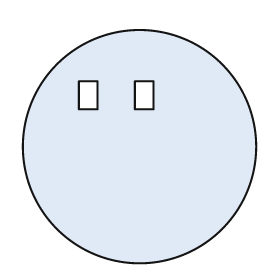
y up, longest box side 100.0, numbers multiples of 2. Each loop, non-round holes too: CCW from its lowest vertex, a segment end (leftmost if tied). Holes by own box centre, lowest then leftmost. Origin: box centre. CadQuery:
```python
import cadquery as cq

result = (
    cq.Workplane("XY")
    .moveTo(0.0, 0.0)
    .circle(50.0)
    .moveTo(-26.0, 16.0)
    .lineTo(-18.0, 16.0)
    .lineTo(-18.0, 28.0)
    .lineTo(-26.0, 28.0)
    .close()
    .moveTo(-2.0, 16.0)
    .lineTo(6.0, 16.0)
    .lineTo(6.0, 28.0)
    .lineTo(-2.0, 28.0)
    .close()
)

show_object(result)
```